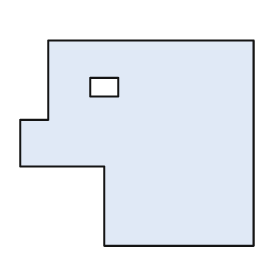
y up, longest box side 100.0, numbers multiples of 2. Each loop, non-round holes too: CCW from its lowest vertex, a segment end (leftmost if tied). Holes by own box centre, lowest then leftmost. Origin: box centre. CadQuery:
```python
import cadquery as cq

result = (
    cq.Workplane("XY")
    .moveTo(-14.0, -44.0)
    .lineTo(50.0, -44.0)
    .lineTo(50.0, 44.0)
    .lineTo(-38.0, 44.0)
    .lineTo(-38.0, 10.0)
    .lineTo(-50.0, 10.0)
    .lineTo(-50.0, -10.0)
    .lineTo(-14.0, -10.0)
    .close()
    .moveTo(-20.0, 20.0)
    .lineTo(-8.0, 20.0)
    .lineTo(-8.0, 28.0)
    .lineTo(-20.0, 28.0)
    .close()
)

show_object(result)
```